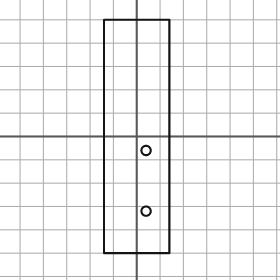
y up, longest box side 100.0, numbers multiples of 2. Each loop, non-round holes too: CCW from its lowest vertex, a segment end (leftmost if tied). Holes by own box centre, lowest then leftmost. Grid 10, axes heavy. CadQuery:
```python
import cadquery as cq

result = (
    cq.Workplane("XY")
    .moveTo(-14.0, -50.0)
    .lineTo(14.0, -50.0)
    .lineTo(14.0, 50.0)
    .lineTo(-14.0, 50.0)
    .close()
    .moveTo(4.0, -32.0)
    .circle(2.0)
    .moveTo(4.0, -6.0)
    .circle(2.0)
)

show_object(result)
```